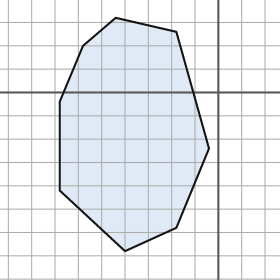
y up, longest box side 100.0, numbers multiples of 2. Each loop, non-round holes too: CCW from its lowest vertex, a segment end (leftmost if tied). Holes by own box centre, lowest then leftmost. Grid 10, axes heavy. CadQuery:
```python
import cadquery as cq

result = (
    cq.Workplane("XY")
    .moveTo(-40.0, -68.0)
    .lineTo(-18.0, -58.0)
    .lineTo(-4.0, -24.0)
    .lineTo(-18.0, 26.0)
    .lineTo(-44.0, 32.0)
    .lineTo(-58.0, 20.0)
    .lineTo(-68.0, -4.0)
    .lineTo(-68.0, -42.0)
    .close()
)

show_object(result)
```